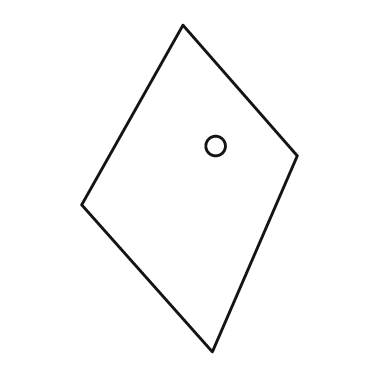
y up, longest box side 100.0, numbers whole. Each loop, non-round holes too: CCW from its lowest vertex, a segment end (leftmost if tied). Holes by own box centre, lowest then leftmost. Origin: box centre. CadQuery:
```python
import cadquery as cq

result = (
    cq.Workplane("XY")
    .moveTo(7.0, -50.0)
    .lineTo(33.0, 10.0)
    .lineTo(-2.0, 50.0)
    .lineTo(-33.0, -5.0)
    .close()
    .moveTo(8.0, 13.0)
    .circle(3.0)
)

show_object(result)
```